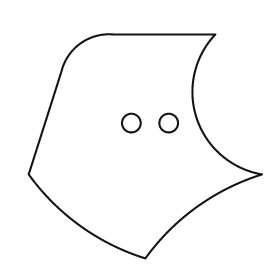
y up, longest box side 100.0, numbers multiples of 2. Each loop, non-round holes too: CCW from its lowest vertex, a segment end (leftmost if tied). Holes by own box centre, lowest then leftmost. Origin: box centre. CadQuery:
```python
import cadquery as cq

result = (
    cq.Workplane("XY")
    .moveTo(0.0, -48.0)
    .threePointArc((22.0, -26.0), (50.0, -12.0))
    .threePointArc((22.0, 12.0), (30.0, 48.0))
    .lineTo(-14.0, 48.0)
    .threePointArc((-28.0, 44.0), (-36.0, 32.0))
    .lineTo(-50.0, -12.0)
    .threePointArc((-28.0, -34.0), (0.0, -48.0))
    .close()
    .moveTo(-6.0, 10.0)
    .circle(4.0)
    .moveTo(10.0, 10.0)
    .circle(4.0)
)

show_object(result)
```